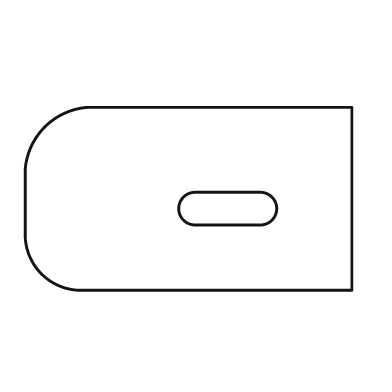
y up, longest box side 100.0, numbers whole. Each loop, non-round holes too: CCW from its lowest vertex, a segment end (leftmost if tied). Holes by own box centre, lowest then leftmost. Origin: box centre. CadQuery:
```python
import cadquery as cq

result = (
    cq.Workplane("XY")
    .moveTo(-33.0, -28.0)
    .lineTo(50.0, -28.0)
    .lineTo(50.0, 28.0)
    .lineTo(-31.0, 28.0)
    .threePointArc((-44.0, 22.0), (-50.0, 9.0))
    .lineTo(-50.0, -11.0)
    .threePointArc((-45.0, -23.0), (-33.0, -28.0))
    .close()
    .moveTo(2.0, -8.0)
    .lineTo(22.0, -8.0)
    .threePointArc((27.0, -3.0), (22.0, 2.0))
    .lineTo(2.0, 2.0)
    .threePointArc((-3.0, -3.0), (2.0, -8.0))
    .close()
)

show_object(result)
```